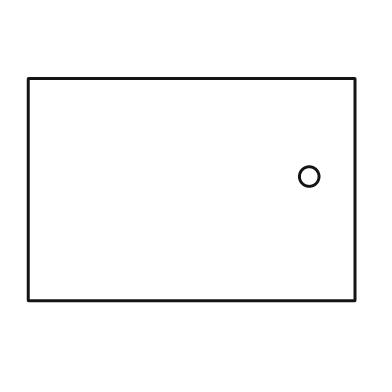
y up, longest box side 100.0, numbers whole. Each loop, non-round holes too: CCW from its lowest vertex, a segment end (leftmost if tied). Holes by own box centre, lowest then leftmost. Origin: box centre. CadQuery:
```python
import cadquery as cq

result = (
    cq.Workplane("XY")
    .moveTo(-50.0, -34.0)
    .lineTo(50.0, -34.0)
    .lineTo(50.0, 34.0)
    .lineTo(-50.0, 34.0)
    .close()
    .moveTo(36.0, 4.0)
    .circle(3.0)
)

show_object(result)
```